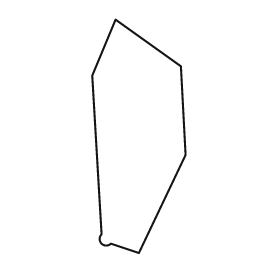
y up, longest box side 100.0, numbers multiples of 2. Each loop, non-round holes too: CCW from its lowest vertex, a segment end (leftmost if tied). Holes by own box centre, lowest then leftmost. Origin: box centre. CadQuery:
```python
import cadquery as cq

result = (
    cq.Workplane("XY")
    .moveTo(0.0, -50.0)
    .lineTo(20.0, -8.0)
    .lineTo(18.0, 30.0)
    .lineTo(-10.0, 50.0)
    .lineTo(-20.0, 26.0)
    .lineTo(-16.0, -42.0)
    .threePointArc((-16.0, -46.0), (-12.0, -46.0))
    .close()
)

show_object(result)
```